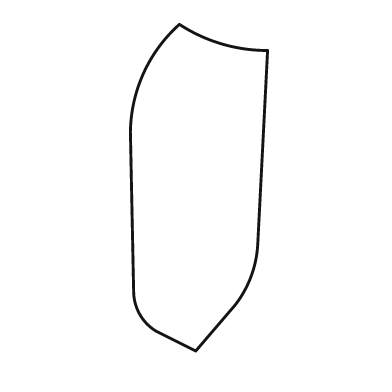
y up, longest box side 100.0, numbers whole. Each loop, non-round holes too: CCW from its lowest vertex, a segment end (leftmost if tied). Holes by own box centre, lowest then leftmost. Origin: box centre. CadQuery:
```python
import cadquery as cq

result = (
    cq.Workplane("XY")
    .moveTo(-1.0, -50.0)
    .lineTo(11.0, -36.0)
    .threePointArc((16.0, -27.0), (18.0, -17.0))
    .lineTo(21.0, 42.0)
    .threePointArc((7.0, 44.0), (-6.0, 50.0))
    .threePointArc((-17.0, 35.0), (-21.0, 17.0))
    .lineTo(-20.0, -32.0)
    .threePointArc((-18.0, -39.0), (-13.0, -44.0))
    .close()
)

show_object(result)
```